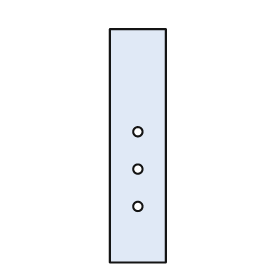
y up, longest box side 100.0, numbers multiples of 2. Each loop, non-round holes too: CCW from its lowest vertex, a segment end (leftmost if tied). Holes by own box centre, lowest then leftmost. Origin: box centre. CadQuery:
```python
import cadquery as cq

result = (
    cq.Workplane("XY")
    .moveTo(-12.0, -50.0)
    .lineTo(12.0, -50.0)
    .lineTo(12.0, 50.0)
    .lineTo(-12.0, 50.0)
    .close()
    .moveTo(0.0, -26.0)
    .circle(2.0)
    .moveTo(0.0, -10.0)
    .circle(2.0)
    .moveTo(0.0, 6.0)
    .circle(2.0)
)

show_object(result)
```